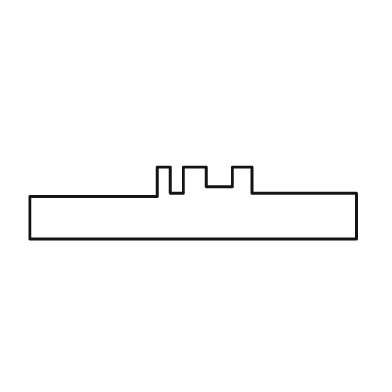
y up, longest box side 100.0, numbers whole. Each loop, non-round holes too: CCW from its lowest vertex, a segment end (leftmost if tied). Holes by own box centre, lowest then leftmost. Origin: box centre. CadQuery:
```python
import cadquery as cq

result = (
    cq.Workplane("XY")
    .moveTo(-50.0, -11.0)
    .lineTo(50.0, -11.0)
    .lineTo(50.0, 3.0)
    .lineTo(18.0, 3.0)
    .lineTo(18.0, 11.0)
    .lineTo(12.0, 11.0)
    .lineTo(12.0, 5.0)
    .lineTo(4.0, 5.0)
    .lineTo(4.0, 11.0)
    .lineTo(-3.0, 11.0)
    .lineTo(-3.0, 3.0)
    .lineTo(-7.0, 3.0)
    .lineTo(-7.0, 11.0)
    .lineTo(-11.0, 11.0)
    .lineTo(-11.0, 2.0)
    .lineTo(-50.0, 2.0)
    .close()
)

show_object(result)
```